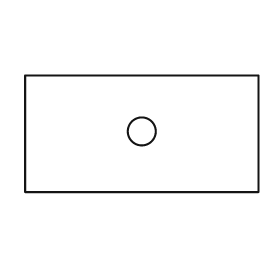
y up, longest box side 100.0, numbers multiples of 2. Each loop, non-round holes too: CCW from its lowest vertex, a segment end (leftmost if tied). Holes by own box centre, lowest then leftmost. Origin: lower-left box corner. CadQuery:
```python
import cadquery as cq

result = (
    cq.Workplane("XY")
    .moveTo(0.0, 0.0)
    .lineTo(100.0, 0.0)
    .lineTo(100.0, 50.0)
    .lineTo(0.0, 50.0)
    .close()
    .moveTo(50.0, 26.0)
    .circle(6.0)
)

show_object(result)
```